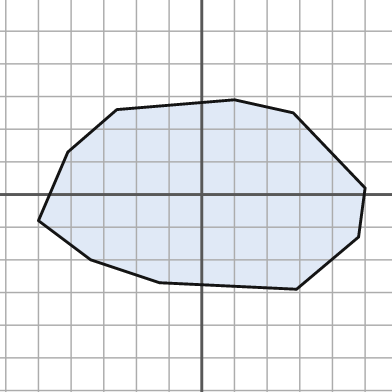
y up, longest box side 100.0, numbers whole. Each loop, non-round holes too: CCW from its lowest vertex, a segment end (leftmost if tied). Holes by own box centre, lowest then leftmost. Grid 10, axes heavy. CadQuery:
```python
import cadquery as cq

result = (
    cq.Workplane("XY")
    .moveTo(29.0, -29.0)
    .lineTo(48.0, -13.0)
    .lineTo(50.0, 2.0)
    .lineTo(28.0, 25.0)
    .lineTo(10.0, 29.0)
    .lineTo(-26.0, 26.0)
    .lineTo(-41.0, 13.0)
    .lineTo(-50.0, -8.0)
    .lineTo(-34.0, -20.0)
    .lineTo(-13.0, -27.0)
    .close()
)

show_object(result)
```